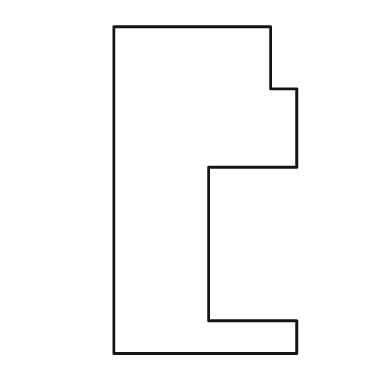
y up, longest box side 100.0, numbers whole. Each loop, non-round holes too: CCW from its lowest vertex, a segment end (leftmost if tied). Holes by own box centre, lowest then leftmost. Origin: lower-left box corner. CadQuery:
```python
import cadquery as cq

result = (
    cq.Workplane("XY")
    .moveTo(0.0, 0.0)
    .lineTo(56.0, 0.0)
    .lineTo(56.0, 10.0)
    .lineTo(29.0, 10.0)
    .lineTo(29.0, 57.0)
    .lineTo(56.0, 57.0)
    .lineTo(56.0, 81.0)
    .lineTo(48.0, 81.0)
    .lineTo(48.0, 100.0)
    .lineTo(0.0, 100.0)
    .close()
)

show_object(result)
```